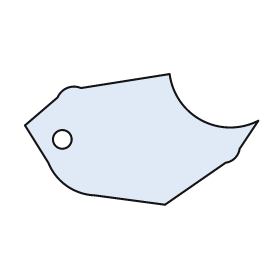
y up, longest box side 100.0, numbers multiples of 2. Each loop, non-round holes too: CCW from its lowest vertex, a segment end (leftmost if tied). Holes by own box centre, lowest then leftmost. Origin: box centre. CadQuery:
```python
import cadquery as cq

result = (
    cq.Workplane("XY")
    .moveTo(10.0, -28.0)
    .lineTo(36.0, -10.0)
    .threePointArc((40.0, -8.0), (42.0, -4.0))
    .lineTo(50.0, 8.0)
    .threePointArc((26.0, 8.0), (12.0, 28.0))
    .lineTo(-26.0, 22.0)
    .threePointArc((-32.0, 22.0), (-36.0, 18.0))
    .lineTo(-50.0, 6.0)
    .lineTo(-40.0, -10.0)
    .threePointArc((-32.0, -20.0), (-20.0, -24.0))
    .close()
    .moveTo(-34.0, 0.0)
    .circle(4.0)
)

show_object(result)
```